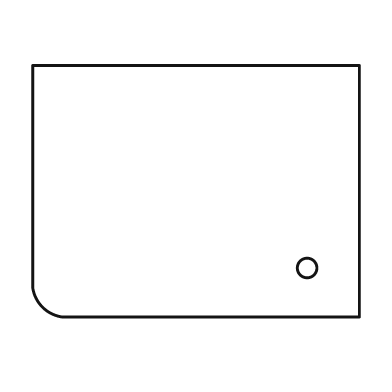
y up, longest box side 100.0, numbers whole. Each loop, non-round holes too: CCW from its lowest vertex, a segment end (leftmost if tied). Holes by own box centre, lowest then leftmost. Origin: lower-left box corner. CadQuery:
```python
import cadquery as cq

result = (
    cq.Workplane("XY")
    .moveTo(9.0, 0.0)
    .lineTo(100.0, 0.0)
    .lineTo(100.0, 77.0)
    .lineTo(0.0, 77.0)
    .lineTo(0.0, 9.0)
    .threePointArc((3.0, 3.0), (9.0, 0.0))
    .close()
    .moveTo(84.0, 15.0)
    .circle(3.0)
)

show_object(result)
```